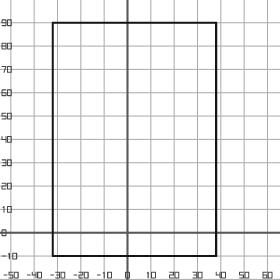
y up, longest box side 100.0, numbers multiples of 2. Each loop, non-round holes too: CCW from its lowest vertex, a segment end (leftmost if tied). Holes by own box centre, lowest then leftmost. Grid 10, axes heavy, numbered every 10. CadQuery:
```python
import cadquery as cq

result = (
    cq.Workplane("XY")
    .moveTo(-32.0, -10.0)
    .lineTo(38.0, -10.0)
    .lineTo(38.0, 90.0)
    .lineTo(-32.0, 90.0)
    .close()
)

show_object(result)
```